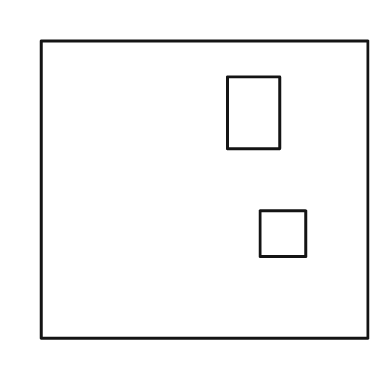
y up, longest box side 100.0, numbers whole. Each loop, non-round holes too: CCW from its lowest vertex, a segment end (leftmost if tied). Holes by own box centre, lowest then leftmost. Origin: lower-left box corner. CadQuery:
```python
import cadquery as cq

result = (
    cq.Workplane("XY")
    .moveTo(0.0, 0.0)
    .lineTo(100.0, 0.0)
    .lineTo(100.0, 91.0)
    .lineTo(0.0, 91.0)
    .close()
    .moveTo(67.0, 25.0)
    .lineTo(81.0, 25.0)
    .lineTo(81.0, 39.0)
    .lineTo(67.0, 39.0)
    .close()
    .moveTo(57.0, 58.0)
    .lineTo(73.0, 58.0)
    .lineTo(73.0, 80.0)
    .lineTo(57.0, 80.0)
    .close()
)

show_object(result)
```